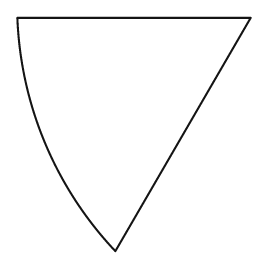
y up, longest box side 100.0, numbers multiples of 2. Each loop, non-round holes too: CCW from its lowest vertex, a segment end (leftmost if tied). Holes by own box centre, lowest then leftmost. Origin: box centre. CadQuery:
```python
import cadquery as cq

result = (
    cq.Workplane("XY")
    .moveTo(-8.0, -50.0)
    .lineTo(50.0, 50.0)
    .lineTo(-50.0, 50.0)
    .threePointArc((-38.0, -4.0), (-8.0, -50.0))
    .close()
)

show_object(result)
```